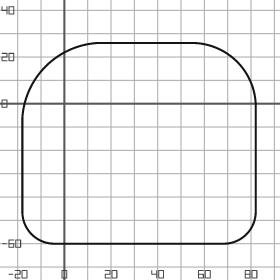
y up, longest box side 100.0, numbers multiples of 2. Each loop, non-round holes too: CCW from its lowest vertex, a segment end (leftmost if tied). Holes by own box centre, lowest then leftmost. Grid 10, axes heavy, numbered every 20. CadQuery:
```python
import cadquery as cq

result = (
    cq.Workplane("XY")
    .moveTo(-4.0, -60.0)
    .lineTo(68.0, -60.0)
    .threePointArc((78.0, -56.0), (82.0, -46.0))
    .lineTo(82.0, 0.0)
    .threePointArc((74.0, 18.0), (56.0, 26.0))
    .lineTo(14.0, 26.0)
    .threePointArc((-8.0, 16.0), (-18.0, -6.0))
    .lineTo(-18.0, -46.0)
    .threePointArc((-14.0, -56.0), (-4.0, -60.0))
    .close()
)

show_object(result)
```